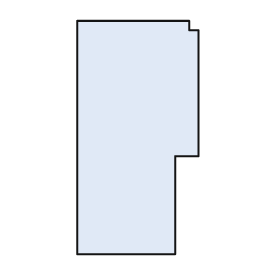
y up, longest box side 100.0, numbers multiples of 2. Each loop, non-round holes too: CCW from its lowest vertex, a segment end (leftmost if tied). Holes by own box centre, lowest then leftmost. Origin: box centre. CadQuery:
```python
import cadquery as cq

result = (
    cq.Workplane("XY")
    .moveTo(-26.0, -50.0)
    .lineTo(16.0, -50.0)
    .lineTo(16.0, -8.0)
    .lineTo(26.0, -8.0)
    .lineTo(26.0, 46.0)
    .lineTo(22.0, 46.0)
    .lineTo(22.0, 50.0)
    .lineTo(-26.0, 50.0)
    .close()
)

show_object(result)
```